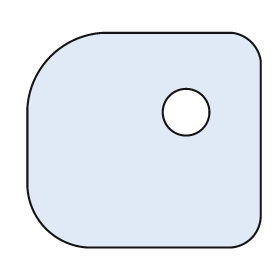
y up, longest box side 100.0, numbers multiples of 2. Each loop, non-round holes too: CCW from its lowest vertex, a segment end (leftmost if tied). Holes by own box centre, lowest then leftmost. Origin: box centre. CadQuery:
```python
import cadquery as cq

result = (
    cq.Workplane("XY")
    .moveTo(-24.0, -46.0)
    .lineTo(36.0, -46.0)
    .threePointArc((46.0, -42.0), (50.0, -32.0))
    .lineTo(50.0, 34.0)
    .threePointArc((46.0, 42.0), (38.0, 46.0))
    .lineTo(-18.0, 46.0)
    .threePointArc((-40.0, 36.0), (-50.0, 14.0))
    .lineTo(-50.0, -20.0)
    .threePointArc((-42.0, -38.0), (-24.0, -46.0))
    .close()
    .moveTo(18.0, 12.0)
    .circle(10.0)
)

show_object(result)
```